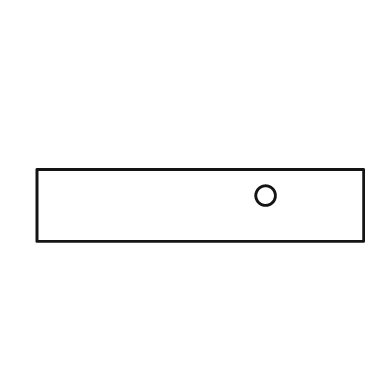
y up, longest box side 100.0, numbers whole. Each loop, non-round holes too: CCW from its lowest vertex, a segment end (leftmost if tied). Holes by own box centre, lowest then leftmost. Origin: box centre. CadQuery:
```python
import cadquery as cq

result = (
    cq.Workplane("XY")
    .moveTo(-50.0, -11.0)
    .lineTo(50.0, -11.0)
    .lineTo(50.0, 11.0)
    .lineTo(-50.0, 11.0)
    .close()
    .moveTo(20.0, 3.0)
    .circle(3.0)
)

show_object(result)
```